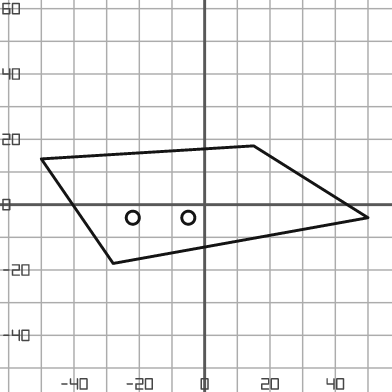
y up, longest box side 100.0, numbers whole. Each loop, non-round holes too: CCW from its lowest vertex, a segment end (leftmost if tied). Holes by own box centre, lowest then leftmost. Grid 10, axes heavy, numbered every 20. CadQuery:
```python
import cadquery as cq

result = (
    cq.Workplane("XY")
    .moveTo(-28.0, -18.0)
    .lineTo(50.0, -4.0)
    .lineTo(15.0, 18.0)
    .lineTo(-50.0, 14.0)
    .close()
    .moveTo(-22.0, -4.0)
    .circle(2.0)
    .moveTo(-5.0, -4.0)
    .circle(2.0)
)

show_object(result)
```